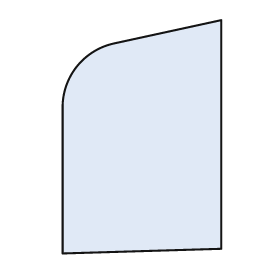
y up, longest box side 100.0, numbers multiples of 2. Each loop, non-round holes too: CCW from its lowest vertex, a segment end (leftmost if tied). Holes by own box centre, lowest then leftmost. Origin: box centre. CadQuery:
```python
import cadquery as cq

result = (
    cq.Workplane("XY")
    .moveTo(-34.0, -50.0)
    .lineTo(34.0, -48.0)
    .lineTo(34.0, 50.0)
    .lineTo(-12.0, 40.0)
    .threePointArc((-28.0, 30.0), (-34.0, 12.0))
    .close()
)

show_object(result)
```